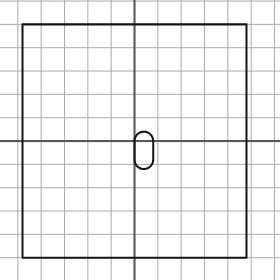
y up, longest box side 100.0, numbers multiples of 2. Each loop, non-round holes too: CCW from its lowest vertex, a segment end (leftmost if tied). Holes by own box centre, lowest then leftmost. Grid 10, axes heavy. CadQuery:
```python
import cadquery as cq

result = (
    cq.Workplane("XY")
    .moveTo(-48.0, -50.0)
    .lineTo(48.0, -50.0)
    .lineTo(48.0, 50.0)
    .lineTo(-48.0, 50.0)
    .close()
    .moveTo(0.0, -8.0)
    .threePointArc((4.0, -12.0), (8.0, -8.0))
    .lineTo(8.0, 0.0)
    .threePointArc((4.0, 4.0), (0.0, 0.0))
    .close()
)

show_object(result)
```